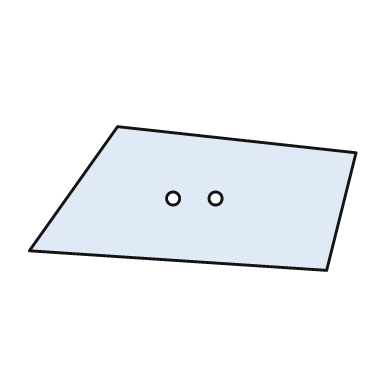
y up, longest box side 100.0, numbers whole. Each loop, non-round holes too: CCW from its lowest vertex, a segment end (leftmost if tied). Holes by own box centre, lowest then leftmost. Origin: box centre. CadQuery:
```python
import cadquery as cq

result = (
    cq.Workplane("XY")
    .moveTo(41.0, -22.0)
    .lineTo(50.0, 14.0)
    .lineTo(-23.0, 22.0)
    .lineTo(-50.0, -16.0)
    .close()
    .moveTo(-6.0, 0.0)
    .circle(2.0)
    .moveTo(7.0, 0.0)
    .circle(2.0)
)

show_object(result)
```